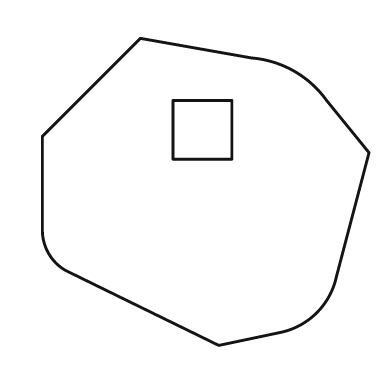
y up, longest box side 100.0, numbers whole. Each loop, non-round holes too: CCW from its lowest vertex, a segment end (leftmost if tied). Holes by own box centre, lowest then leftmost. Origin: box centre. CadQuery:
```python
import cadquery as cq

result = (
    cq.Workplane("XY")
    .moveTo(4.0, -47.0)
    .lineTo(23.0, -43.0)
    .threePointArc((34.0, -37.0), (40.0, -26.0))
    .lineTo(50.0, 12.0)
    .lineTo(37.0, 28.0)
    .threePointArc((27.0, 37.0), (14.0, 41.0))
    .lineTo(-20.0, 47.0)
    .lineTo(-50.0, 17.0)
    .lineTo(-50.0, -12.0)
    .threePointArc((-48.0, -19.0), (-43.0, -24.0))
    .close()
    .moveTo(-10.0, 10.0)
    .lineTo(8.0, 10.0)
    .lineTo(8.0, 28.0)
    .lineTo(-10.0, 28.0)
    .close()
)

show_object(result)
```